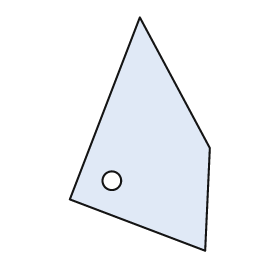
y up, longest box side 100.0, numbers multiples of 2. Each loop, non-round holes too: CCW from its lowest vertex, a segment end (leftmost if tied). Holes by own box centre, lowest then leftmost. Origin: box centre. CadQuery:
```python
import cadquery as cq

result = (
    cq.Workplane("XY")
    .moveTo(28.0, -50.0)
    .lineTo(30.0, -6.0)
    .lineTo(0.0, 50.0)
    .lineTo(-30.0, -28.0)
    .close()
    .moveTo(-12.0, -20.0)
    .circle(4.0)
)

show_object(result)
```